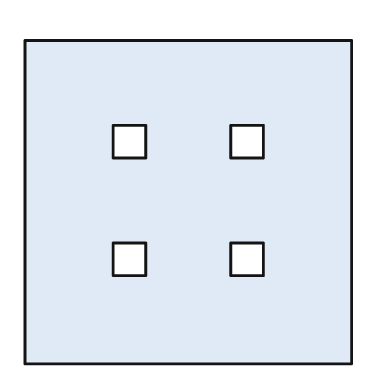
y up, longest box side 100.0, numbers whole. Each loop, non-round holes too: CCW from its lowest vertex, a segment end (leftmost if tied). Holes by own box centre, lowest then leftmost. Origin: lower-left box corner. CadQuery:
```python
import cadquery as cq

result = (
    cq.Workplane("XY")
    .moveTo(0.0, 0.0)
    .lineTo(100.0, 0.0)
    .lineTo(100.0, 99.0)
    .lineTo(0.0, 99.0)
    .close()
    .moveTo(27.0, 27.0)
    .lineTo(37.0, 27.0)
    .lineTo(37.0, 37.0)
    .lineTo(27.0, 37.0)
    .close()
    .moveTo(63.0, 27.0)
    .lineTo(73.0, 27.0)
    .lineTo(73.0, 37.0)
    .lineTo(63.0, 37.0)
    .close()
    .moveTo(27.0, 63.0)
    .lineTo(37.0, 63.0)
    .lineTo(37.0, 73.0)
    .lineTo(27.0, 73.0)
    .close()
    .moveTo(63.0, 63.0)
    .lineTo(73.0, 63.0)
    .lineTo(73.0, 73.0)
    .lineTo(63.0, 73.0)
    .close()
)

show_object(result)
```